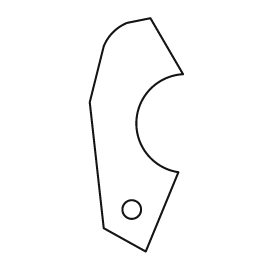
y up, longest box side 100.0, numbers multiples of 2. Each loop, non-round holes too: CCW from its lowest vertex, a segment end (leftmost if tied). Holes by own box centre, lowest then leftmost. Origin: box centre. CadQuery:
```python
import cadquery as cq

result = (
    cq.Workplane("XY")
    .moveTo(4.0, -50.0)
    .lineTo(18.0, -16.0)
    .threePointArc((0.0, 6.0), (20.0, 26.0))
    .lineTo(6.0, 50.0)
    .lineTo(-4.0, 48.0)
    .threePointArc((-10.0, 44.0), (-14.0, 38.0))
    .lineTo(-20.0, 14.0)
    .lineTo(-14.0, -40.0)
    .close()
    .moveTo(-2.0, -32.0)
    .circle(4.0)
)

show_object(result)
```